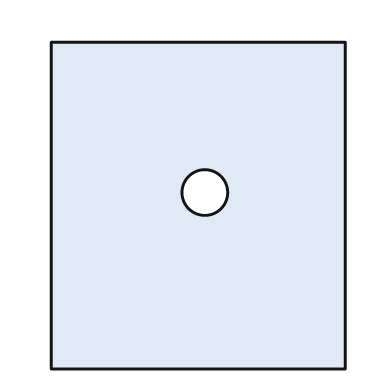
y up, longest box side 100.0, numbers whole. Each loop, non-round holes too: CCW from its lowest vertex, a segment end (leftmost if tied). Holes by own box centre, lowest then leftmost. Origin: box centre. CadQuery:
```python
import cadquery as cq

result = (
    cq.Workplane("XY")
    .moveTo(-45.0, -50.0)
    .lineTo(45.0, -50.0)
    .lineTo(45.0, 50.0)
    .lineTo(-45.0, 50.0)
    .close()
    .moveTo(2.0, 4.0)
    .circle(7.0)
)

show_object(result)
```